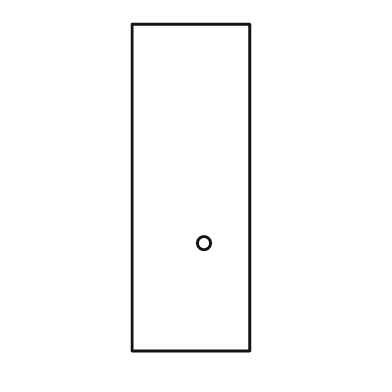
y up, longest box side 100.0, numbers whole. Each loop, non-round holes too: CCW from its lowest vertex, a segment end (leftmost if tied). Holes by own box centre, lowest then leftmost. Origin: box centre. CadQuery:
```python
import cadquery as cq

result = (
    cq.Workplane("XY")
    .moveTo(-18.0, -50.0)
    .lineTo(18.0, -50.0)
    .lineTo(18.0, 50.0)
    .lineTo(-18.0, 50.0)
    .close()
    .moveTo(4.0, -17.0)
    .circle(2.0)
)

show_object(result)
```